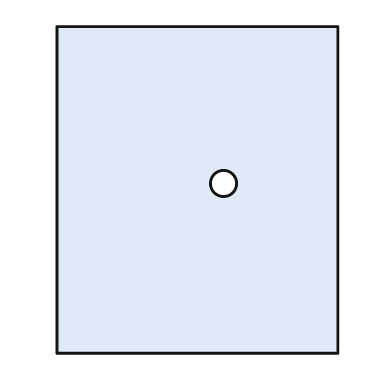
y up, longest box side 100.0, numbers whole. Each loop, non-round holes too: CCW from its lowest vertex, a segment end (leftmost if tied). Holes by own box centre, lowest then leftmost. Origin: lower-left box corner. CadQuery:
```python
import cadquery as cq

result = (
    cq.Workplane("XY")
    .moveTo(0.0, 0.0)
    .lineTo(86.0, 0.0)
    .lineTo(86.0, 100.0)
    .lineTo(0.0, 100.0)
    .close()
    .moveTo(51.0, 52.0)
    .circle(4.0)
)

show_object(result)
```